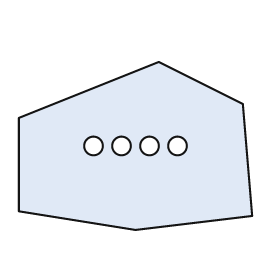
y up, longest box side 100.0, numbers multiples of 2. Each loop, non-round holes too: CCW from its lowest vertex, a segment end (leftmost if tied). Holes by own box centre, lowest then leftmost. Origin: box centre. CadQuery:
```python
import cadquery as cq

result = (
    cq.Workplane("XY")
    .moveTo(0.0, -36.0)
    .lineTo(50.0, -30.0)
    .lineTo(46.0, 18.0)
    .lineTo(10.0, 36.0)
    .lineTo(-50.0, 12.0)
    .lineTo(-50.0, -28.0)
    .close()
    .moveTo(-18.0, 0.0)
    .circle(4.0)
    .moveTo(-6.0, 0.0)
    .circle(4.0)
    .moveTo(6.0, 0.0)
    .circle(4.0)
    .moveTo(18.0, 0.0)
    .circle(4.0)
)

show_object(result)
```